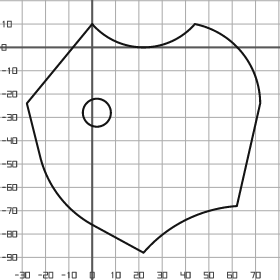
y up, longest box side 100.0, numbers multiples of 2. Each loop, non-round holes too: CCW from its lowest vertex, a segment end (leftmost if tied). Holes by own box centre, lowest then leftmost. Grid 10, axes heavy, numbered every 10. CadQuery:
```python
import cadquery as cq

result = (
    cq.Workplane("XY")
    .moveTo(22.0, -88.0)
    .threePointArc((40.0, -74.0), (62.0, -68.0))
    .lineTo(72.0, -24.0)
    .threePointArc((64.0, -2.0), (44.0, 10.0))
    .threePointArc((22.0, 0.0), (0.0, 10.0))
    .lineTo(-28.0, -24.0)
    .lineTo(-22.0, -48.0)
    .threePointArc((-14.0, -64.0), (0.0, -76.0))
    .close()
    .moveTo(2.0, -28.0)
    .circle(6.0)
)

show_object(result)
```